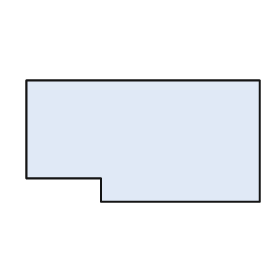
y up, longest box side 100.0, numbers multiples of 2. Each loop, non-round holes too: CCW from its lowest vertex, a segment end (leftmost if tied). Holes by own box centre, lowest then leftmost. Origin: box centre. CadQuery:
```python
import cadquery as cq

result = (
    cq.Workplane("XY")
    .moveTo(-18.0, -26.0)
    .lineTo(50.0, -26.0)
    .lineTo(50.0, 26.0)
    .lineTo(-50.0, 26.0)
    .lineTo(-50.0, -16.0)
    .lineTo(-18.0, -16.0)
    .close()
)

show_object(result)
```